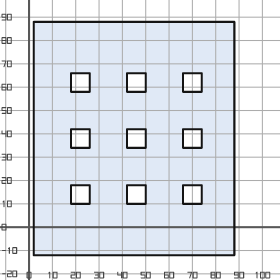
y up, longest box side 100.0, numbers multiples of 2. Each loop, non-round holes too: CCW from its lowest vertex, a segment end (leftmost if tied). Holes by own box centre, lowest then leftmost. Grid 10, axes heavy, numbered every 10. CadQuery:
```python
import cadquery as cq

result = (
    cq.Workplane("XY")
    .moveTo(2.0, -12.0)
    .lineTo(88.0, -12.0)
    .lineTo(88.0, 88.0)
    .lineTo(2.0, 88.0)
    .close()
    .moveTo(18.0, 10.0)
    .lineTo(26.0, 10.0)
    .lineTo(26.0, 18.0)
    .lineTo(18.0, 18.0)
    .close()
    .moveTo(42.0, 10.0)
    .lineTo(50.0, 10.0)
    .lineTo(50.0, 18.0)
    .lineTo(42.0, 18.0)
    .close()
    .moveTo(66.0, 10.0)
    .lineTo(74.0, 10.0)
    .lineTo(74.0, 18.0)
    .lineTo(66.0, 18.0)
    .close()
    .moveTo(18.0, 34.0)
    .lineTo(26.0, 34.0)
    .lineTo(26.0, 42.0)
    .lineTo(18.0, 42.0)
    .close()
    .moveTo(42.0, 34.0)
    .lineTo(50.0, 34.0)
    .lineTo(50.0, 42.0)
    .lineTo(42.0, 42.0)
    .close()
    .moveTo(66.0, 34.0)
    .lineTo(74.0, 34.0)
    .lineTo(74.0, 42.0)
    .lineTo(66.0, 42.0)
    .close()
    .moveTo(18.0, 58.0)
    .lineTo(26.0, 58.0)
    .lineTo(26.0, 66.0)
    .lineTo(18.0, 66.0)
    .close()
    .moveTo(42.0, 58.0)
    .lineTo(50.0, 58.0)
    .lineTo(50.0, 66.0)
    .lineTo(42.0, 66.0)
    .close()
    .moveTo(66.0, 58.0)
    .lineTo(74.0, 58.0)
    .lineTo(74.0, 66.0)
    .lineTo(66.0, 66.0)
    .close()
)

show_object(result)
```